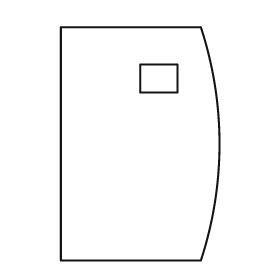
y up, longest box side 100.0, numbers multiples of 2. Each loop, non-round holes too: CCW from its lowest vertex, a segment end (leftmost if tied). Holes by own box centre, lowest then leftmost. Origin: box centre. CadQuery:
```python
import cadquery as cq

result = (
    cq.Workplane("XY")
    .moveTo(-34.0, -50.0)
    .lineTo(26.0, -50.0)
    .threePointArc((34.0, 0.0), (26.0, 50.0))
    .lineTo(-34.0, 50.0)
    .close()
    .moveTo(0.0, 22.0)
    .lineTo(16.0, 22.0)
    .lineTo(16.0, 34.0)
    .lineTo(0.0, 34.0)
    .close()
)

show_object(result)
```